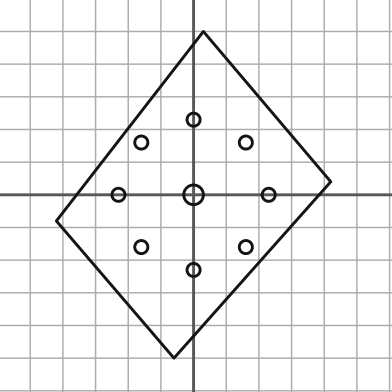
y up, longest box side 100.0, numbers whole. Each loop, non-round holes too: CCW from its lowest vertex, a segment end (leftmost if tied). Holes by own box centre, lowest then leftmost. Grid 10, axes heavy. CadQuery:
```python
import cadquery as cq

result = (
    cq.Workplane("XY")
    .moveTo(-6.0, -50.0)
    .lineTo(42.0, 4.0)
    .lineTo(3.0, 50.0)
    .lineTo(-42.0, -8.0)
    .close()
    .moveTo(0.0, -23.0)
    .circle(2.0)
    .moveTo(-16.0, -16.0)
    .circle(2.0)
    .moveTo(16.0, -16.0)
    .circle(2.0)
    .moveTo(-23.0, 0.0)
    .circle(2.0)
    .moveTo(0.0, 0.0)
    .circle(3.0)
    .moveTo(23.0, 0.0)
    .circle(2.0)
    .moveTo(-16.0, 16.0)
    .circle(2.0)
    .moveTo(16.0, 16.0)
    .circle(2.0)
    .moveTo(0.0, 23.0)
    .circle(2.0)
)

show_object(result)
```